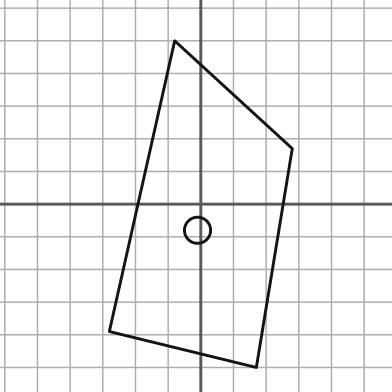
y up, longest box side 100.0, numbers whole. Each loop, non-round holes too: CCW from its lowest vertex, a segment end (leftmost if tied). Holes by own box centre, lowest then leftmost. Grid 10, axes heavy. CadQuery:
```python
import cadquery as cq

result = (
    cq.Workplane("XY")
    .moveTo(17.0, -50.0)
    .lineTo(28.0, 17.0)
    .lineTo(-8.0, 50.0)
    .lineTo(-28.0, -39.0)
    .close()
    .moveTo(-1.0, -8.0)
    .circle(4.0)
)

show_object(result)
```